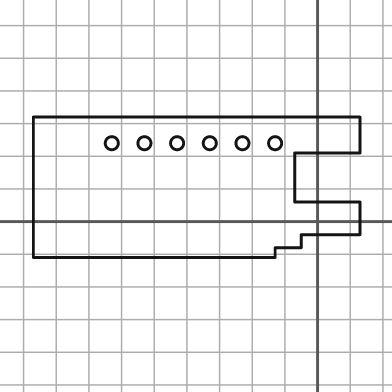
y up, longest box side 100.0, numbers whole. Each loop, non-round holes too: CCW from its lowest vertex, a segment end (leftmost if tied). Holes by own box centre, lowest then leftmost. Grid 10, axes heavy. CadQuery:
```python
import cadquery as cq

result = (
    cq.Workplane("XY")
    .moveTo(-87.0, -11.0)
    .lineTo(-13.0, -11.0)
    .lineTo(-13.0, -8.0)
    .lineTo(-5.0, -8.0)
    .lineTo(-5.0, -4.0)
    .lineTo(13.0, -4.0)
    .lineTo(13.0, 6.0)
    .lineTo(-7.0, 6.0)
    .lineTo(-7.0, 21.0)
    .lineTo(13.0, 21.0)
    .lineTo(13.0, 32.0)
    .lineTo(-87.0, 32.0)
    .close()
    .moveTo(-63.0, 24.0)
    .circle(2.0)
    .moveTo(-53.0, 24.0)
    .circle(2.0)
    .moveTo(-43.0, 24.0)
    .circle(2.0)
    .moveTo(-33.0, 24.0)
    .circle(2.0)
    .moveTo(-23.0, 24.0)
    .circle(2.0)
    .moveTo(-13.0, 24.0)
    .circle(2.0)
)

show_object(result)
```